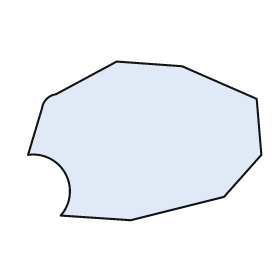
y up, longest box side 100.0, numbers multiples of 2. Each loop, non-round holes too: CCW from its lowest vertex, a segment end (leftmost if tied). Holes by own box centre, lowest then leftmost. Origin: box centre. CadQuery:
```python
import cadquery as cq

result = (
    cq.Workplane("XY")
    .moveTo(-6.0, -34.0)
    .lineTo(34.0, -24.0)
    .lineTo(50.0, -6.0)
    .lineTo(48.0, 18.0)
    .lineTo(16.0, 32.0)
    .lineTo(-12.0, 34.0)
    .lineTo(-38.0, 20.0)
    .threePointArc((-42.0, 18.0), (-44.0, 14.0))
    .lineTo(-50.0, -6.0)
    .threePointArc((-34.0, -14.0), (-36.0, -32.0))
    .close()
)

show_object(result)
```